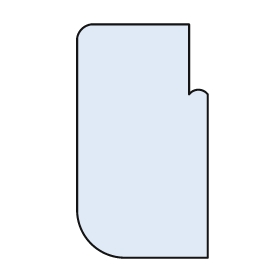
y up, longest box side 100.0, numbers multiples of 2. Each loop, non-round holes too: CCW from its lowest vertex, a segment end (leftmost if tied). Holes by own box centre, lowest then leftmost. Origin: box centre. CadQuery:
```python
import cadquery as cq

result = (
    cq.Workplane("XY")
    .moveTo(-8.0, -50.0)
    .lineTo(28.0, -50.0)
    .lineTo(28.0, 20.0)
    .threePointArc((24.0, 22.0), (20.0, 20.0))
    .lineTo(20.0, 50.0)
    .lineTo(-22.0, 50.0)
    .threePointArc((-26.0, 48.0), (-28.0, 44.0))
    .lineTo(-28.0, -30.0)
    .threePointArc((-22.0, -44.0), (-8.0, -50.0))
    .close()
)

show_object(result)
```